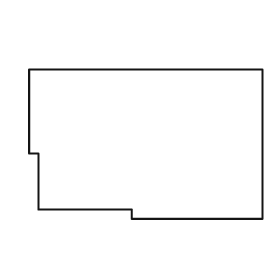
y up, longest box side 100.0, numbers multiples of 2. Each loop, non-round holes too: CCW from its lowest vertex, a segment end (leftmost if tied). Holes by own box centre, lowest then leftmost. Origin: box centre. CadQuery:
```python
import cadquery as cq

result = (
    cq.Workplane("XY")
    .moveTo(-6.0, -32.0)
    .lineTo(50.0, -32.0)
    .lineTo(50.0, 32.0)
    .lineTo(-50.0, 32.0)
    .lineTo(-50.0, -4.0)
    .lineTo(-46.0, -4.0)
    .lineTo(-46.0, -28.0)
    .lineTo(-6.0, -28.0)
    .close()
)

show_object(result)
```